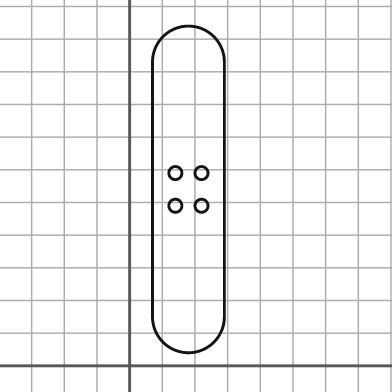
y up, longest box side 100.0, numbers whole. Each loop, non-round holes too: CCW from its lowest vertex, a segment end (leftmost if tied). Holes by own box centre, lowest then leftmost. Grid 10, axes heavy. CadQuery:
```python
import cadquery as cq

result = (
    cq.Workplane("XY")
    .moveTo(7.0, 15.0)
    .threePointArc((18.0, 4.0), (29.0, 15.0))
    .lineTo(29.0, 93.0)
    .threePointArc((18.0, 104.0), (7.0, 93.0))
    .close()
    .moveTo(14.0, 49.0)
    .circle(2.0)
    .moveTo(22.0, 49.0)
    .circle(2.0)
    .moveTo(14.0, 59.0)
    .circle(2.0)
    .moveTo(22.0, 59.0)
    .circle(2.0)
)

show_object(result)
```